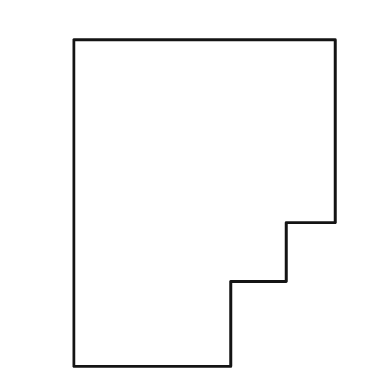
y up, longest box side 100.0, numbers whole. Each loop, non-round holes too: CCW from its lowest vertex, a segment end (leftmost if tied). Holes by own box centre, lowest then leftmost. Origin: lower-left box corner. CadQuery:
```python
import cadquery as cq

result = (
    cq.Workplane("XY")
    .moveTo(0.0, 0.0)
    .lineTo(48.0, 0.0)
    .lineTo(48.0, 26.0)
    .lineTo(65.0, 26.0)
    .lineTo(65.0, 44.0)
    .lineTo(80.0, 44.0)
    .lineTo(80.0, 100.0)
    .lineTo(0.0, 100.0)
    .close()
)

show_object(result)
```